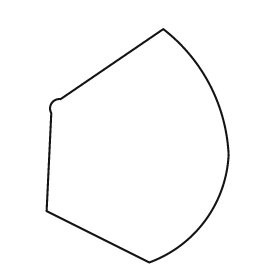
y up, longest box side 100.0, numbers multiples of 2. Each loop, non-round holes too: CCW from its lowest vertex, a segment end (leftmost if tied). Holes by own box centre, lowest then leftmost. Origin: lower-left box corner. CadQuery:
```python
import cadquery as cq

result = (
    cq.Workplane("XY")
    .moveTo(44.0, 0.0)
    .threePointArc((68.0, 18.0), (78.0, 46.0))
    .threePointArc((70.0, 76.0), (50.0, 100.0))
    .lineTo(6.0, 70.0)
    .threePointArc((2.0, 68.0), (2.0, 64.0))
    .lineTo(0.0, 22.0)
    .close()
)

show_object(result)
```